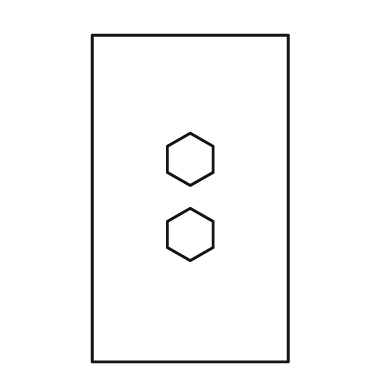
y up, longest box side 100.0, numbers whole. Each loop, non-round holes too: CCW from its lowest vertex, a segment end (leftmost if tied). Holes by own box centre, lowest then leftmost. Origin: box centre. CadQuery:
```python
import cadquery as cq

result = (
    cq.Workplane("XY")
    .moveTo(-30.0, -50.0)
    .lineTo(30.0, -50.0)
    .lineTo(30.0, 50.0)
    .lineTo(-30.0, 50.0)
    .close()
    .moveTo(0.0, -19.0)
    .lineTo(7.0, -15.0)
    .lineTo(7.0, -7.0)
    .lineTo(0.0, -3.0)
    .lineTo(-7.0, -7.0)
    .lineTo(-7.0, -15.0)
    .close()
    .moveTo(0.0, 4.0)
    .lineTo(7.0, 8.0)
    .lineTo(7.0, 16.0)
    .lineTo(0.0, 20.0)
    .lineTo(-7.0, 16.0)
    .lineTo(-7.0, 8.0)
    .close()
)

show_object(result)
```